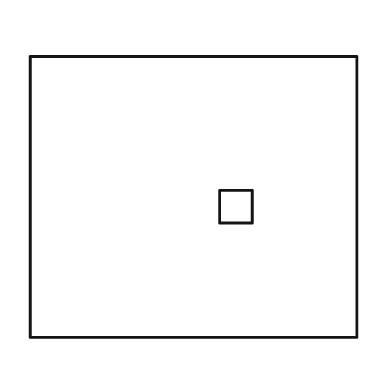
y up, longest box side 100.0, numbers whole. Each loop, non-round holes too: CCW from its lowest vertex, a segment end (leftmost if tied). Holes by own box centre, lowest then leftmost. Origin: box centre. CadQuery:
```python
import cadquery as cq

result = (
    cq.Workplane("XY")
    .moveTo(-50.0, -43.0)
    .lineTo(50.0, -43.0)
    .lineTo(50.0, 43.0)
    .lineTo(-50.0, 43.0)
    .close()
    .moveTo(8.0, -8.0)
    .lineTo(18.0, -8.0)
    .lineTo(18.0, 2.0)
    .lineTo(8.0, 2.0)
    .close()
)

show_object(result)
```